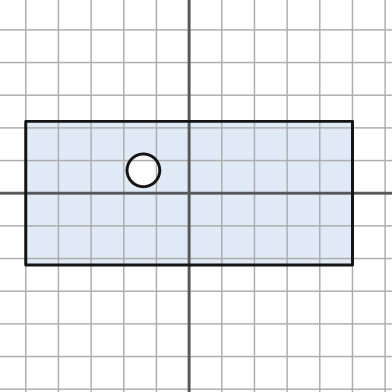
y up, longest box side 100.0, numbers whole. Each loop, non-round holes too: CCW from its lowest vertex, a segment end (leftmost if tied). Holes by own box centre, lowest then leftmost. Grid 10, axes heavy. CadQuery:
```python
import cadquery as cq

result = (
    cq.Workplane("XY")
    .moveTo(-50.0, -22.0)
    .lineTo(50.0, -22.0)
    .lineTo(50.0, 22.0)
    .lineTo(-50.0, 22.0)
    .close()
    .moveTo(-14.0, 7.0)
    .circle(5.0)
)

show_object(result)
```